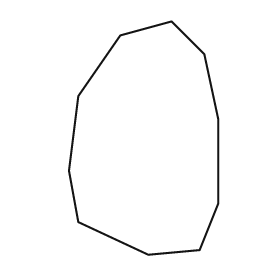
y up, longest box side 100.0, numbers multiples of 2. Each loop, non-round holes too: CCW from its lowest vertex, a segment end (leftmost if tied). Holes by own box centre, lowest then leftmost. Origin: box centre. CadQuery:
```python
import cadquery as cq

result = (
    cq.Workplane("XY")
    .moveTo(2.0, -50.0)
    .lineTo(24.0, -48.0)
    .lineTo(32.0, -28.0)
    .lineTo(32.0, 8.0)
    .lineTo(26.0, 36.0)
    .lineTo(12.0, 50.0)
    .lineTo(-10.0, 44.0)
    .lineTo(-28.0, 18.0)
    .lineTo(-32.0, -14.0)
    .lineTo(-28.0, -36.0)
    .close()
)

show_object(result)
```